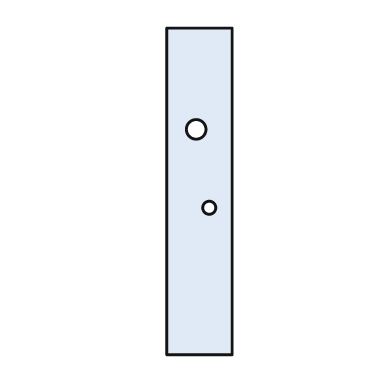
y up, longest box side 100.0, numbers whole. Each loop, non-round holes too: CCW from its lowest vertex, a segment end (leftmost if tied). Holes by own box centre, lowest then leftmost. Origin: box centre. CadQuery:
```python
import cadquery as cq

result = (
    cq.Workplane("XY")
    .moveTo(-10.0, -50.0)
    .lineTo(10.0, -50.0)
    .lineTo(10.0, 50.0)
    .lineTo(-10.0, 50.0)
    .close()
    .moveTo(3.0, -5.0)
    .circle(2.0)
    .moveTo(-1.0, 19.0)
    .circle(3.0)
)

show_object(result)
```